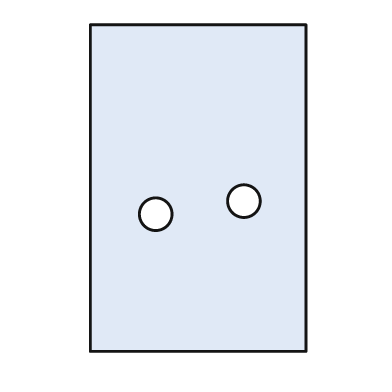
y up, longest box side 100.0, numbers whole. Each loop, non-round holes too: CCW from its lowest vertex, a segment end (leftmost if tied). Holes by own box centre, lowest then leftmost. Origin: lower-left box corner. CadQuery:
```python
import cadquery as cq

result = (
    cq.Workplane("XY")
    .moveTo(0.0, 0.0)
    .lineTo(66.0, 0.0)
    .lineTo(66.0, 100.0)
    .lineTo(0.0, 100.0)
    .close()
    .moveTo(20.0, 42.0)
    .circle(5.0)
    .moveTo(47.0, 46.0)
    .circle(5.0)
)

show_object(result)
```